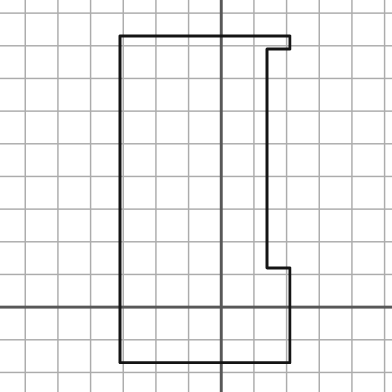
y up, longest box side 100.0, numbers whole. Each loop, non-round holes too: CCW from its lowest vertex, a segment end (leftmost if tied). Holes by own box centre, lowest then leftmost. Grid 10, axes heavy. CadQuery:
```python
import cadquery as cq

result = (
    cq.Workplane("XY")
    .moveTo(-31.0, -17.0)
    .lineTo(21.0, -17.0)
    .lineTo(21.0, 12.0)
    .lineTo(14.0, 12.0)
    .lineTo(14.0, 79.0)
    .lineTo(21.0, 79.0)
    .lineTo(21.0, 83.0)
    .lineTo(-31.0, 83.0)
    .close()
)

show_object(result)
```